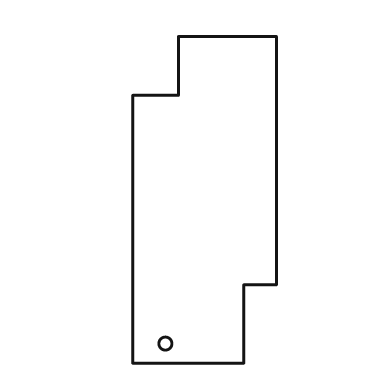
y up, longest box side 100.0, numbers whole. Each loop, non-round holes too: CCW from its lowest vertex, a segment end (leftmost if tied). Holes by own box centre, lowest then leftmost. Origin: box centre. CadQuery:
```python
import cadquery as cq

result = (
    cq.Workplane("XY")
    .moveTo(-22.0, -50.0)
    .lineTo(12.0, -50.0)
    .lineTo(12.0, -26.0)
    .lineTo(22.0, -26.0)
    .lineTo(22.0, 50.0)
    .lineTo(-8.0, 50.0)
    .lineTo(-8.0, 32.0)
    .lineTo(-22.0, 32.0)
    .close()
    .moveTo(-12.0, -44.0)
    .circle(2.0)
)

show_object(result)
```